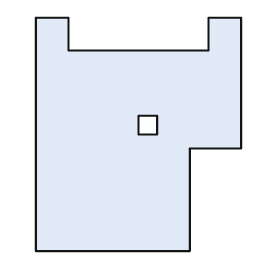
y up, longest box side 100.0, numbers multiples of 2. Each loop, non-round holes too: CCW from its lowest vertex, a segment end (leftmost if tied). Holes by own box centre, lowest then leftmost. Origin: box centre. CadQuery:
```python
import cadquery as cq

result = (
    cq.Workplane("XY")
    .moveTo(-44.0, -50.0)
    .lineTo(22.0, -50.0)
    .lineTo(22.0, -6.0)
    .lineTo(44.0, -6.0)
    .lineTo(44.0, 50.0)
    .lineTo(30.0, 50.0)
    .lineTo(30.0, 36.0)
    .lineTo(-30.0, 36.0)
    .lineTo(-30.0, 50.0)
    .lineTo(-44.0, 50.0)
    .close()
    .moveTo(0.0, 0.0)
    .lineTo(8.0, 0.0)
    .lineTo(8.0, 8.0)
    .lineTo(0.0, 8.0)
    .close()
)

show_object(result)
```